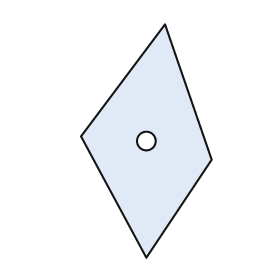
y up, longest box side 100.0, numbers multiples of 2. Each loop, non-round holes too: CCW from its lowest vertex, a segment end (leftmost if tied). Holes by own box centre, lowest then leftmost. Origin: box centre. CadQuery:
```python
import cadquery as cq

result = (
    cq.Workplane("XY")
    .moveTo(0.0, -50.0)
    .lineTo(28.0, -8.0)
    .lineTo(8.0, 50.0)
    .lineTo(-28.0, 2.0)
    .close()
    .moveTo(0.0, 0.0)
    .circle(4.0)
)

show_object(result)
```